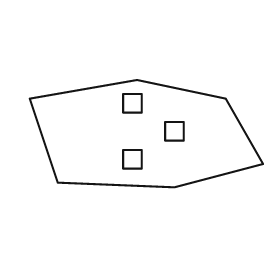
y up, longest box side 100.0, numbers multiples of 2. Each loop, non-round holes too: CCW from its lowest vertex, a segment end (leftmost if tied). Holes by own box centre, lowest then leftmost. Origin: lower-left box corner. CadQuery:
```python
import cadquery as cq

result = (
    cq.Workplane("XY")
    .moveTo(62.0, 0.0)
    .lineTo(100.0, 10.0)
    .lineTo(84.0, 38.0)
    .lineTo(46.0, 46.0)
    .lineTo(0.0, 38.0)
    .lineTo(12.0, 2.0)
    .close()
    .moveTo(40.0, 8.0)
    .lineTo(48.0, 8.0)
    .lineTo(48.0, 16.0)
    .lineTo(40.0, 16.0)
    .close()
    .moveTo(58.0, 20.0)
    .lineTo(66.0, 20.0)
    .lineTo(66.0, 28.0)
    .lineTo(58.0, 28.0)
    .close()
    .moveTo(40.0, 32.0)
    .lineTo(48.0, 32.0)
    .lineTo(48.0, 40.0)
    .lineTo(40.0, 40.0)
    .close()
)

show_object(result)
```